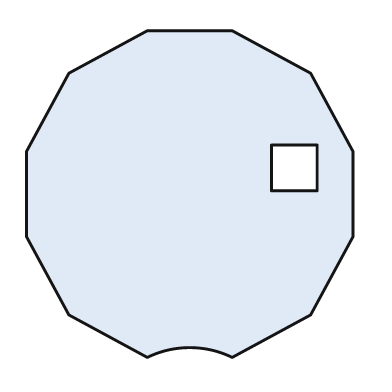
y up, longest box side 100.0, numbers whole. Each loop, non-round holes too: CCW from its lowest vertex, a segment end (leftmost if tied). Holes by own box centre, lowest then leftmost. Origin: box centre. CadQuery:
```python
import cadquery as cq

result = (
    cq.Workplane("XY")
    .moveTo(-13.0, -50.0)
    .threePointArc((0.0, -47.0), (13.0, -50.0))
    .lineTo(37.0, -37.0)
    .lineTo(50.0, -13.0)
    .lineTo(50.0, 13.0)
    .lineTo(37.0, 37.0)
    .lineTo(13.0, 50.0)
    .lineTo(-13.0, 50.0)
    .lineTo(-37.0, 37.0)
    .lineTo(-50.0, 13.0)
    .lineTo(-50.0, -13.0)
    .lineTo(-37.0, -37.0)
    .close()
    .moveTo(25.0, 1.0)
    .lineTo(39.0, 1.0)
    .lineTo(39.0, 15.0)
    .lineTo(25.0, 15.0)
    .close()
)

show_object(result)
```